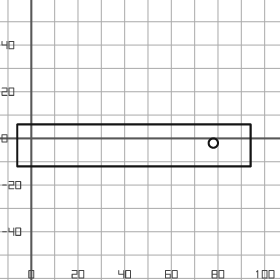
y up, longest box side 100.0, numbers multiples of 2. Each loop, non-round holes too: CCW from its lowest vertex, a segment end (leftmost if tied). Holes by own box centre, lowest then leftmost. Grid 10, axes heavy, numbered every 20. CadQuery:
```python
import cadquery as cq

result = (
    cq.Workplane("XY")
    .moveTo(-6.0, -12.0)
    .lineTo(94.0, -12.0)
    .lineTo(94.0, 6.0)
    .lineTo(-6.0, 6.0)
    .close()
    .moveTo(78.0, -2.0)
    .circle(2.0)
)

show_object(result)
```